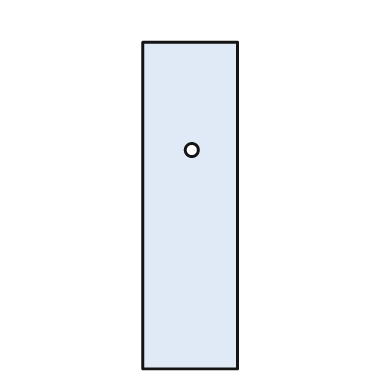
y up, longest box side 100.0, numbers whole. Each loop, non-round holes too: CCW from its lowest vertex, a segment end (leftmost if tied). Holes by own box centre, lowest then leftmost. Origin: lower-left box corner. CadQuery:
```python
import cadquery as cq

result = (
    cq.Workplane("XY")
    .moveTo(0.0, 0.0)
    .lineTo(29.0, 0.0)
    .lineTo(29.0, 100.0)
    .lineTo(0.0, 100.0)
    .close()
    .moveTo(15.0, 67.0)
    .circle(2.0)
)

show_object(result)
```